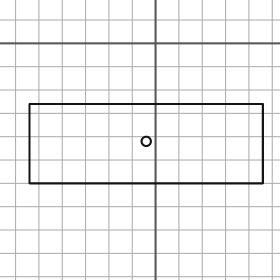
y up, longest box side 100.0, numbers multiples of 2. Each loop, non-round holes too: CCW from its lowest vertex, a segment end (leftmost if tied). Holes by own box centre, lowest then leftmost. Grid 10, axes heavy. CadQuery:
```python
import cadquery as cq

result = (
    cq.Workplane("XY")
    .moveTo(-54.0, -60.0)
    .lineTo(46.0, -60.0)
    .lineTo(46.0, -26.0)
    .lineTo(-54.0, -26.0)
    .close()
    .moveTo(-4.0, -42.0)
    .circle(2.0)
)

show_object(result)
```